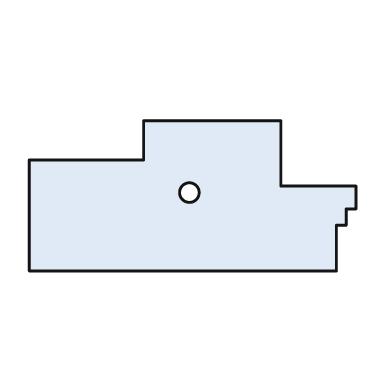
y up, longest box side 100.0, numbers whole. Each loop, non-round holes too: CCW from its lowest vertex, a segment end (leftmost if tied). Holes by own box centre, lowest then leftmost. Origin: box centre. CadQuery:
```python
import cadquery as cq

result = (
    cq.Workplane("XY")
    .moveTo(-50.0, -23.0)
    .lineTo(44.0, -23.0)
    .lineTo(44.0, -9.0)
    .lineTo(47.0, -9.0)
    .lineTo(47.0, -4.0)
    .lineTo(50.0, -4.0)
    .lineTo(50.0, 3.0)
    .lineTo(27.0, 3.0)
    .lineTo(27.0, 23.0)
    .lineTo(-15.0, 23.0)
    .lineTo(-15.0, 11.0)
    .lineTo(-50.0, 11.0)
    .close()
    .moveTo(-1.0, 1.0)
    .circle(3.0)
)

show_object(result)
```